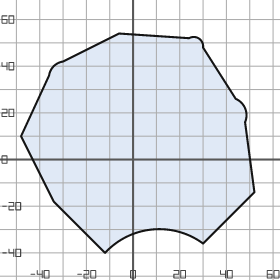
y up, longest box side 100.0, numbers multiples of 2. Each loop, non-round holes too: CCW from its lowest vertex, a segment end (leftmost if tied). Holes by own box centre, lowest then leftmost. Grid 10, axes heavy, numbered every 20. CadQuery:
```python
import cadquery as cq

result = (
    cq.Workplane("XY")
    .moveTo(-12.0, -40.0)
    .threePointArc((8.0, -30.0), (30.0, -36.0))
    .lineTo(52.0, -14.0)
    .lineTo(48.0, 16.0)
    .threePointArc((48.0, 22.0), (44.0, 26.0))
    .lineTo(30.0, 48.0)
    .threePointArc((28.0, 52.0), (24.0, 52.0))
    .lineTo(-6.0, 54.0)
    .lineTo(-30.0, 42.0)
    .threePointArc((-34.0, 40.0), (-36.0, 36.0))
    .lineTo(-48.0, 10.0)
    .lineTo(-34.0, -18.0)
    .close()
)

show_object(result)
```